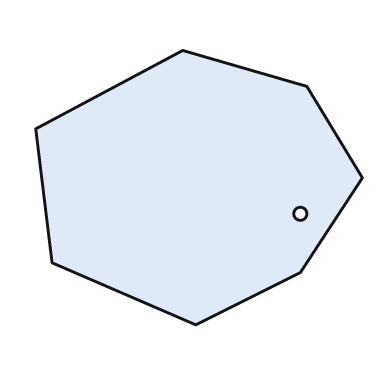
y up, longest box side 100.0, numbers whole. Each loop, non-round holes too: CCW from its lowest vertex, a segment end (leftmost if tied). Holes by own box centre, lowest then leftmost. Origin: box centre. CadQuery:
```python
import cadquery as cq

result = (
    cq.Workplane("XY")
    .moveTo(-1.0, -42.0)
    .lineTo(31.0, -26.0)
    .lineTo(50.0, 3.0)
    .lineTo(33.0, 31.0)
    .lineTo(-5.0, 42.0)
    .lineTo(-50.0, 18.0)
    .lineTo(-45.0, -23.0)
    .close()
    .moveTo(31.0, -8.0)
    .circle(2.0)
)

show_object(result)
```